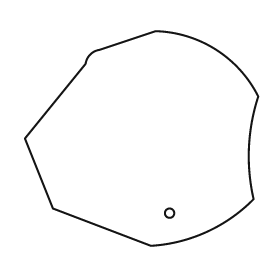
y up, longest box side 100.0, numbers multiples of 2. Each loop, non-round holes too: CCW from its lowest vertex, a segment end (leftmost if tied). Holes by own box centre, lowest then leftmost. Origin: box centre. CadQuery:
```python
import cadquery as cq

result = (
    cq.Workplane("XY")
    .moveTo(4.0, -46.0)
    .threePointArc((28.0, -40.0), (48.0, -26.0))
    .threePointArc((46.0, -4.0), (50.0, 18.0))
    .threePointArc((32.0, 38.0), (6.0, 46.0))
    .lineTo(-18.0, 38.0)
    .threePointArc((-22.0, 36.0), (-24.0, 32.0))
    .lineTo(-50.0, 0.0)
    .lineTo(-38.0, -30.0)
    .close()
    .moveTo(12.0, -32.0)
    .circle(2.0)
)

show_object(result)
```